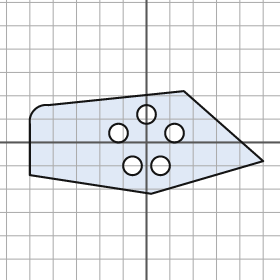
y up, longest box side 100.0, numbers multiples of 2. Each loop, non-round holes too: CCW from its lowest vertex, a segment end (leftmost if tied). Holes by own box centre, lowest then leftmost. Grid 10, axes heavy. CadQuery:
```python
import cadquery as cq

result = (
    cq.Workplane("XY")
    .moveTo(2.0, -22.0)
    .lineTo(50.0, -8.0)
    .lineTo(16.0, 22.0)
    .lineTo(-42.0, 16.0)
    .threePointArc((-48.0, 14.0), (-50.0, 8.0))
    .lineTo(-50.0, -14.0)
    .close()
    .moveTo(-6.0, -10.0)
    .circle(4.0)
    .moveTo(6.0, -10.0)
    .circle(4.0)
    .moveTo(-12.0, 4.0)
    .circle(4.0)
    .moveTo(12.0, 4.0)
    .circle(4.0)
    .moveTo(0.0, 12.0)
    .circle(4.0)
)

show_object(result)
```